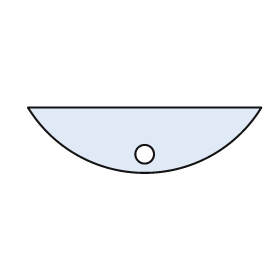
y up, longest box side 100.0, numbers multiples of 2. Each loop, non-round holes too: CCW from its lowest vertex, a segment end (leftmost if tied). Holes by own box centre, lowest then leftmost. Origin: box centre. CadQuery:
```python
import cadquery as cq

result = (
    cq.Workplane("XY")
    .moveTo(-50.0, 14.0)
    .threePointArc((0.0, -14.0), (50.0, 14.0))
    .close()
    .moveTo(0.0, -6.0)
    .circle(4.0)
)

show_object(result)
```